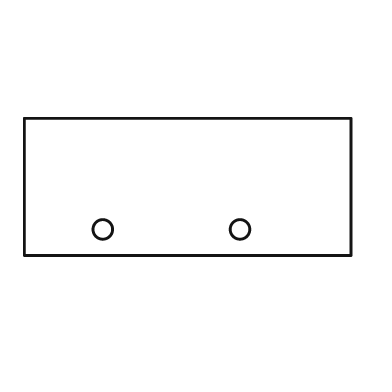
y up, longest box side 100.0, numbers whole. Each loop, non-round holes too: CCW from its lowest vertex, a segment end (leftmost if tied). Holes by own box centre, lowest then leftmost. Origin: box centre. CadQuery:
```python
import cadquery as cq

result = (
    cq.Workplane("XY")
    .moveTo(-50.0, -21.0)
    .lineTo(50.0, -21.0)
    .lineTo(50.0, 21.0)
    .lineTo(-50.0, 21.0)
    .close()
    .moveTo(-26.0, -13.0)
    .circle(3.0)
    .moveTo(16.0, -13.0)
    .circle(3.0)
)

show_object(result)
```